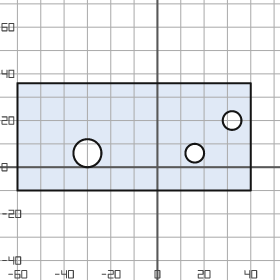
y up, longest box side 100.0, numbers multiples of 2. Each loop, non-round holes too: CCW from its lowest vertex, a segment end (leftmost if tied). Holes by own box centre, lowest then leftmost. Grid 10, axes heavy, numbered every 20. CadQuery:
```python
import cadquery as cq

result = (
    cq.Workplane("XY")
    .moveTo(-60.0, -10.0)
    .lineTo(40.0, -10.0)
    .lineTo(40.0, 36.0)
    .lineTo(-60.0, 36.0)
    .close()
    .moveTo(-30.0, 6.0)
    .circle(6.0)
    .moveTo(16.0, 6.0)
    .circle(4.0)
    .moveTo(32.0, 20.0)
    .circle(4.0)
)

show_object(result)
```